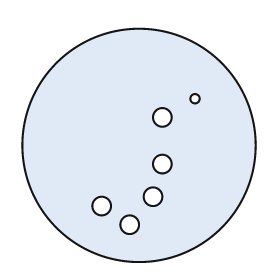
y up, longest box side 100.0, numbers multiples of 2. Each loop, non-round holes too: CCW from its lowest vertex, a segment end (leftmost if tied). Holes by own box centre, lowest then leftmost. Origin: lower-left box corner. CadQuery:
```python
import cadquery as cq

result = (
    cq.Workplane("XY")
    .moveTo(50.0, 50.0)
    .circle(50.0)
    .moveTo(46.0, 16.0)
    .circle(4.0)
    .moveTo(34.0, 24.0)
    .circle(4.0)
    .moveTo(56.0, 28.0)
    .circle(4.0)
    .moveTo(60.0, 42.0)
    .circle(4.0)
    .moveTo(60.0, 62.0)
    .circle(4.0)
    .moveTo(74.0, 70.0)
    .circle(2.0)
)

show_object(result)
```